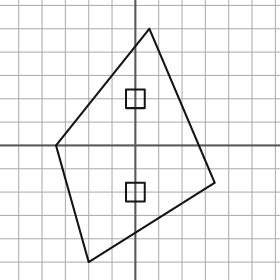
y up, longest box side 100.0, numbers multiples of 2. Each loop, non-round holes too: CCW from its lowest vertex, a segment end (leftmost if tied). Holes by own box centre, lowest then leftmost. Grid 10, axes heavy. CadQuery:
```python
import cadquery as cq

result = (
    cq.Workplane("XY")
    .moveTo(-20.0, -50.0)
    .lineTo(34.0, -16.0)
    .lineTo(6.0, 50.0)
    .lineTo(-34.0, 0.0)
    .close()
    .moveTo(-4.0, -24.0)
    .lineTo(4.0, -24.0)
    .lineTo(4.0, -16.0)
    .lineTo(-4.0, -16.0)
    .close()
    .moveTo(-4.0, 16.0)
    .lineTo(4.0, 16.0)
    .lineTo(4.0, 24.0)
    .lineTo(-4.0, 24.0)
    .close()
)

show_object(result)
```